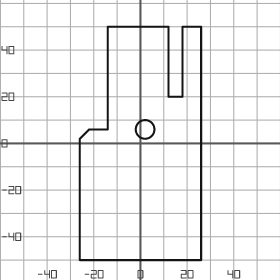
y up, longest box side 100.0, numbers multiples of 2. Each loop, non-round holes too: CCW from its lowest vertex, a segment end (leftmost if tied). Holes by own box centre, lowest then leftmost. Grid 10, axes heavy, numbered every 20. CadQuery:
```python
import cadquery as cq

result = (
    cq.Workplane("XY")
    .moveTo(-26.0, -50.0)
    .lineTo(26.0, -50.0)
    .lineTo(26.0, 50.0)
    .lineTo(18.0, 50.0)
    .lineTo(18.0, 20.0)
    .lineTo(12.0, 20.0)
    .lineTo(12.0, 50.0)
    .lineTo(-14.0, 50.0)
    .lineTo(-14.0, 6.0)
    .lineTo(-22.0, 6.0)
    .lineTo(-26.0, 2.0)
    .close()
    .moveTo(2.0, 6.0)
    .circle(4.0)
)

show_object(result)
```